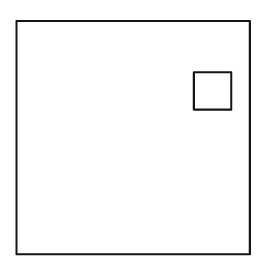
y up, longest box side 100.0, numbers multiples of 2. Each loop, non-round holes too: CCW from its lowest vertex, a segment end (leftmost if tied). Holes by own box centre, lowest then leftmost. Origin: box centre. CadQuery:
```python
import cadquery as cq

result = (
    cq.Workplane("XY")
    .moveTo(-50.0, -50.0)
    .lineTo(50.0, -50.0)
    .lineTo(50.0, 50.0)
    .lineTo(-50.0, 50.0)
    .close()
    .moveTo(26.0, 12.0)
    .lineTo(42.0, 12.0)
    .lineTo(42.0, 28.0)
    .lineTo(26.0, 28.0)
    .close()
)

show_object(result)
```